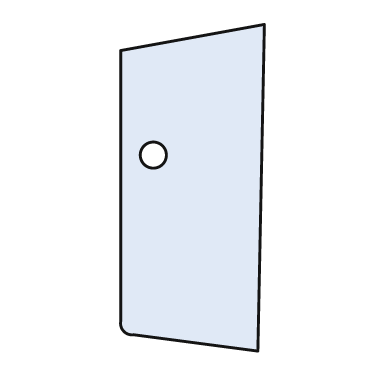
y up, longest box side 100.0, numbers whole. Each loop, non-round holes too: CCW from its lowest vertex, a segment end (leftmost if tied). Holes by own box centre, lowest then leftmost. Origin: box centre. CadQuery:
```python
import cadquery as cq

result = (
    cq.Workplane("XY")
    .moveTo(20.0, -50.0)
    .lineTo(22.0, 50.0)
    .lineTo(-22.0, 42.0)
    .lineTo(-22.0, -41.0)
    .threePointArc((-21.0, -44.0), (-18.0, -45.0))
    .close()
    .moveTo(-12.0, 10.0)
    .circle(4.0)
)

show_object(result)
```